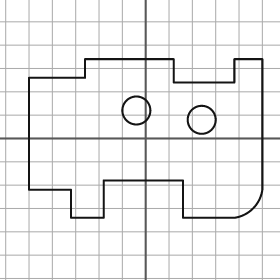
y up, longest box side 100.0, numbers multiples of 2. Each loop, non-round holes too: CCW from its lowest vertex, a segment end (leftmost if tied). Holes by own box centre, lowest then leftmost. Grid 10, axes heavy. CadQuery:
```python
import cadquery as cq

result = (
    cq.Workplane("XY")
    .moveTo(-32.0, -34.0)
    .lineTo(-18.0, -34.0)
    .lineTo(-18.0, -18.0)
    .lineTo(16.0, -18.0)
    .lineTo(16.0, -34.0)
    .lineTo(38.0, -34.0)
    .threePointArc((46.0, -30.0), (50.0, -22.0))
    .lineTo(50.0, 34.0)
    .lineTo(38.0, 34.0)
    .lineTo(38.0, 24.0)
    .lineTo(12.0, 24.0)
    .lineTo(12.0, 34.0)
    .lineTo(-26.0, 34.0)
    .lineTo(-26.0, 26.0)
    .lineTo(-50.0, 26.0)
    .lineTo(-50.0, -22.0)
    .lineTo(-32.0, -22.0)
    .close()
    .moveTo(24.0, 8.0)
    .circle(6.0)
    .moveTo(-4.0, 12.0)
    .circle(6.0)
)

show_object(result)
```